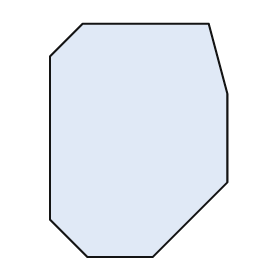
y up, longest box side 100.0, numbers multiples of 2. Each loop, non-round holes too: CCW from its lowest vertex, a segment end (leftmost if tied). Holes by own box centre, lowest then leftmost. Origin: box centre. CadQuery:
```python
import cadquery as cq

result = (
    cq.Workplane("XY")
    .moveTo(-22.0, -50.0)
    .lineTo(6.0, -50.0)
    .lineTo(38.0, -18.0)
    .lineTo(38.0, 20.0)
    .lineTo(30.0, 50.0)
    .lineTo(-24.0, 50.0)
    .lineTo(-38.0, 36.0)
    .lineTo(-38.0, -34.0)
    .close()
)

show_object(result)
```